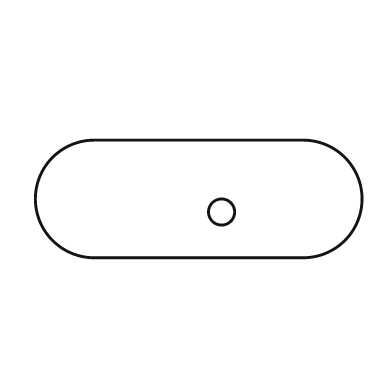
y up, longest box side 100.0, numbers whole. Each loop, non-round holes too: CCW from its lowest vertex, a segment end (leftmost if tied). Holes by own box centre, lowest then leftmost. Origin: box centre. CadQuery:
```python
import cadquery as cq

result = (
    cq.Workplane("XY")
    .moveTo(-32.0, -18.0)
    .lineTo(32.0, -18.0)
    .threePointArc((50.0, 0.0), (32.0, 18.0))
    .lineTo(-32.0, 18.0)
    .threePointArc((-50.0, 0.0), (-32.0, -18.0))
    .close()
    .moveTo(7.0, -4.0)
    .circle(4.0)
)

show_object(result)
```